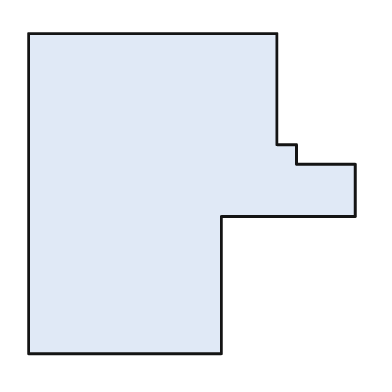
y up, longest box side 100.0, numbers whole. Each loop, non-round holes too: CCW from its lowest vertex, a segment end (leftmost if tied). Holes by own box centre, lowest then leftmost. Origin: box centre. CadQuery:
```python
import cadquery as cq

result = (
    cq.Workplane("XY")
    .moveTo(-50.0, -49.0)
    .lineTo(9.0, -49.0)
    .lineTo(9.0, -7.0)
    .lineTo(50.0, -7.0)
    .lineTo(50.0, 9.0)
    .lineTo(32.0, 9.0)
    .lineTo(32.0, 15.0)
    .lineTo(26.0, 15.0)
    .lineTo(26.0, 49.0)
    .lineTo(-50.0, 49.0)
    .close()
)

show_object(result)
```